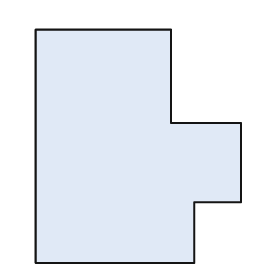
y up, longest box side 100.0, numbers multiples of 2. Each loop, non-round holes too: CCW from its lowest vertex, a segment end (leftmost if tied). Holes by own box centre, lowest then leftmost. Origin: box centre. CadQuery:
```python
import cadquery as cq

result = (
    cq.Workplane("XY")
    .moveTo(-44.0, -50.0)
    .lineTo(24.0, -50.0)
    .lineTo(24.0, -24.0)
    .lineTo(44.0, -24.0)
    .lineTo(44.0, 10.0)
    .lineTo(14.0, 10.0)
    .lineTo(14.0, 50.0)
    .lineTo(-44.0, 50.0)
    .close()
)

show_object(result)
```